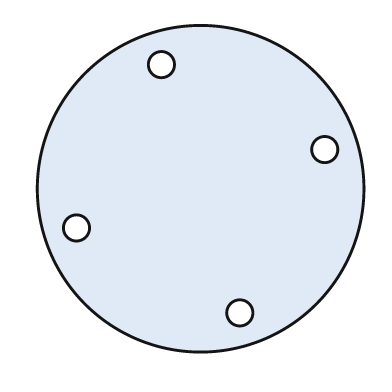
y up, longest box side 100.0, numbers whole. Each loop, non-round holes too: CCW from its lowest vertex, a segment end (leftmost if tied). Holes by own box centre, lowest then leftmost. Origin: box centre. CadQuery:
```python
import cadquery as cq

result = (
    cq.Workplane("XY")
    .moveTo(0.0, 0.0)
    .circle(50.0)
    .moveTo(12.0, -38.0)
    .circle(4.0)
    .moveTo(-38.0, -12.0)
    .circle(4.0)
    .moveTo(38.0, 12.0)
    .circle(4.0)
    .moveTo(-12.0, 38.0)
    .circle(4.0)
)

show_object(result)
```